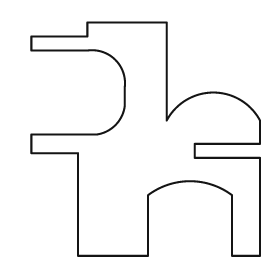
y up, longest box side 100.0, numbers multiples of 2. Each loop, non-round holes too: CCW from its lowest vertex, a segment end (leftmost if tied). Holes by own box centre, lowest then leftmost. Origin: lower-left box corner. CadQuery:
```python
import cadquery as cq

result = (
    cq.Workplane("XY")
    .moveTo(20.0, 0.0)
    .lineTo(50.0, 0.0)
    .lineTo(50.0, 26.0)
    .threePointArc((68.0, 32.0), (86.0, 26.0))
    .lineTo(86.0, 0.0)
    .lineTo(98.0, 0.0)
    .lineTo(98.0, 42.0)
    .lineTo(70.0, 42.0)
    .lineTo(70.0, 48.0)
    .lineTo(98.0, 48.0)
    .lineTo(98.0, 58.0)
    .threePointArc((78.0, 70.0), (58.0, 58.0))
    .lineTo(58.0, 100.0)
    .lineTo(24.0, 100.0)
    .lineTo(24.0, 94.0)
    .lineTo(0.0, 94.0)
    .lineTo(0.0, 88.0)
    .lineTo(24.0, 88.0)
    .threePointArc((36.0, 84.0), (40.0, 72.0))
    .lineTo(40.0, 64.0)
    .threePointArc((36.0, 56.0), (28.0, 52.0))
    .lineTo(0.0, 52.0)
    .lineTo(0.0, 44.0)
    .lineTo(20.0, 44.0)
    .close()
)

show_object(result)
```